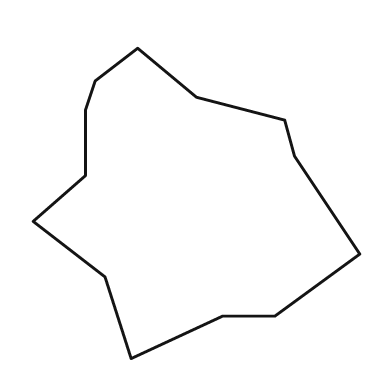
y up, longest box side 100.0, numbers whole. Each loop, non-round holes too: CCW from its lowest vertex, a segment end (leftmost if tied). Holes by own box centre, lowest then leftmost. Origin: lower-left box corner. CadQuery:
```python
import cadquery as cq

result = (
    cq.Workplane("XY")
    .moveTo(30.0, 0.0)
    .lineTo(58.0, 13.0)
    .lineTo(74.0, 13.0)
    .lineTo(100.0, 32.0)
    .lineTo(80.0, 62.0)
    .lineTo(77.0, 73.0)
    .lineTo(50.0, 80.0)
    .lineTo(32.0, 95.0)
    .lineTo(19.0, 85.0)
    .lineTo(16.0, 76.0)
    .lineTo(16.0, 56.0)
    .lineTo(0.0, 42.0)
    .lineTo(22.0, 25.0)
    .close()
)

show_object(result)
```